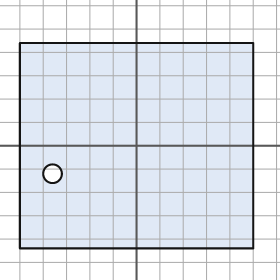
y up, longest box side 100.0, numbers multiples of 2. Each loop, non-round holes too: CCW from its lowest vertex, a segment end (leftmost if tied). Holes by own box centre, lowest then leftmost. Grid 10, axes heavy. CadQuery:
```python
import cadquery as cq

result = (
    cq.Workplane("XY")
    .moveTo(-50.0, -44.0)
    .lineTo(50.0, -44.0)
    .lineTo(50.0, 44.0)
    .lineTo(-50.0, 44.0)
    .close()
    .moveTo(-36.0, -12.0)
    .circle(4.0)
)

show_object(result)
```